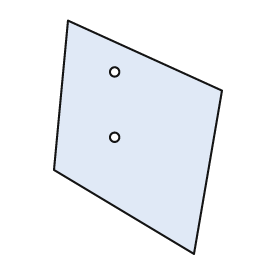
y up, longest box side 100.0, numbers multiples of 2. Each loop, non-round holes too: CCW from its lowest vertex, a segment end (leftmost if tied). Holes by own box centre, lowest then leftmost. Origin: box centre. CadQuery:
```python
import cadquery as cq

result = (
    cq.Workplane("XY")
    .moveTo(24.0, -50.0)
    .lineTo(36.0, 20.0)
    .lineTo(-30.0, 50.0)
    .lineTo(-36.0, -14.0)
    .close()
    .moveTo(-10.0, 0.0)
    .circle(2.0)
    .moveTo(-10.0, 28.0)
    .circle(2.0)
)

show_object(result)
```